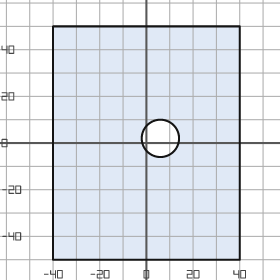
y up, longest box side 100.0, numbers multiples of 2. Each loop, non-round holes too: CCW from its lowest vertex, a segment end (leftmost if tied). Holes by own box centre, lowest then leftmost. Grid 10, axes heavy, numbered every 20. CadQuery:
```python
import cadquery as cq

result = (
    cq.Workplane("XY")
    .moveTo(-40.0, -50.0)
    .lineTo(40.0, -50.0)
    .lineTo(40.0, 50.0)
    .lineTo(-40.0, 50.0)
    .close()
    .moveTo(6.0, 2.0)
    .circle(8.0)
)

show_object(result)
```